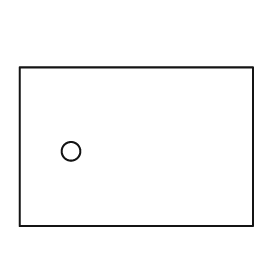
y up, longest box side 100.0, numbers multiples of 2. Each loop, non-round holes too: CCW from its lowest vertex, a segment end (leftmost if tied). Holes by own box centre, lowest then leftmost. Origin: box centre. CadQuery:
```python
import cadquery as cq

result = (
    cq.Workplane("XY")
    .moveTo(-50.0, -34.0)
    .lineTo(50.0, -34.0)
    .lineTo(50.0, 34.0)
    .lineTo(-50.0, 34.0)
    .close()
    .moveTo(-28.0, -2.0)
    .circle(4.0)
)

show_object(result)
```